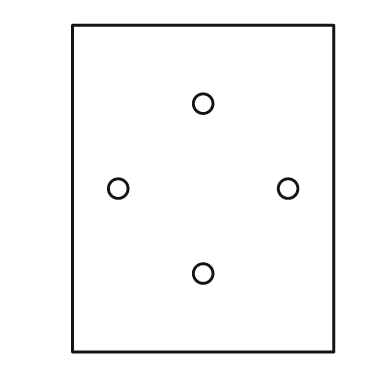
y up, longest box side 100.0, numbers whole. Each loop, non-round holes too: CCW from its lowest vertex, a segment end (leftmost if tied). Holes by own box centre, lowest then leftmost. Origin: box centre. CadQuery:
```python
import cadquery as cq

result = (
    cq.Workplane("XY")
    .moveTo(-40.0, -50.0)
    .lineTo(40.0, -50.0)
    .lineTo(40.0, 50.0)
    .lineTo(-40.0, 50.0)
    .close()
    .moveTo(0.0, -26.0)
    .circle(3.0)
    .moveTo(-26.0, 0.0)
    .circle(3.0)
    .moveTo(26.0, 0.0)
    .circle(3.0)
    .moveTo(0.0, 26.0)
    .circle(3.0)
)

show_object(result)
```